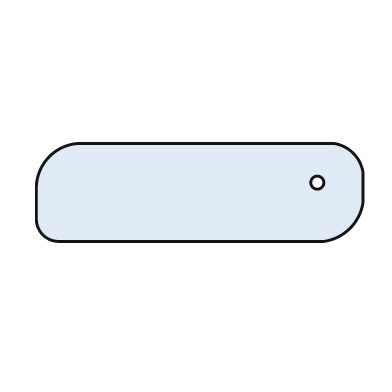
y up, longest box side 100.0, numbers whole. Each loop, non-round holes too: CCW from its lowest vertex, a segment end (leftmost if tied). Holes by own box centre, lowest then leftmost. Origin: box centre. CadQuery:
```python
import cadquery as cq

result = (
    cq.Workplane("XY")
    .moveTo(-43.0, -15.0)
    .lineTo(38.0, -15.0)
    .threePointArc((46.0, -11.0), (50.0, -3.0))
    .lineTo(50.0, 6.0)
    .threePointArc((47.0, 12.0), (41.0, 15.0))
    .lineTo(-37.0, 15.0)
    .threePointArc((-46.0, 11.0), (-50.0, 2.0))
    .lineTo(-50.0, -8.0)
    .threePointArc((-48.0, -13.0), (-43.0, -15.0))
    .close()
    .moveTo(36.0, 3.0)
    .circle(2.0)
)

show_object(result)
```